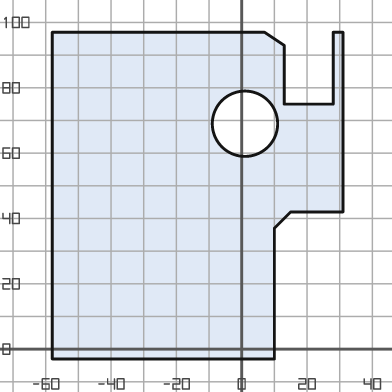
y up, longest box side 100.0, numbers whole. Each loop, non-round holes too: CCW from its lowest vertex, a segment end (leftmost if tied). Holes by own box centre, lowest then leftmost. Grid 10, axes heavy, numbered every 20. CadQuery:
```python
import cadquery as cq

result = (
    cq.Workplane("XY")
    .moveTo(-58.0, -3.0)
    .lineTo(10.0, -3.0)
    .lineTo(10.0, 37.0)
    .lineTo(15.0, 42.0)
    .lineTo(31.0, 42.0)
    .lineTo(31.0, 97.0)
    .lineTo(28.0, 97.0)
    .lineTo(28.0, 75.0)
    .lineTo(13.0, 75.0)
    .lineTo(13.0, 93.0)
    .lineTo(7.0, 97.0)
    .lineTo(-58.0, 97.0)
    .close()
    .moveTo(1.0, 69.0)
    .circle(10.0)
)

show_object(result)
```